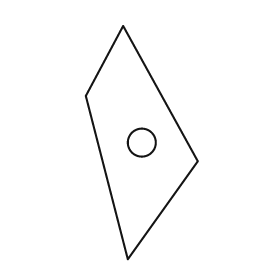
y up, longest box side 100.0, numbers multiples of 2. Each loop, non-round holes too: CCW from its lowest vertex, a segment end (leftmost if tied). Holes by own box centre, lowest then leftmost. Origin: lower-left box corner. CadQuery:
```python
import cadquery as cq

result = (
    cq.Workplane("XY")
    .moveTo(18.0, 0.0)
    .lineTo(48.0, 42.0)
    .lineTo(16.0, 100.0)
    .lineTo(0.0, 70.0)
    .close()
    .moveTo(24.0, 50.0)
    .circle(6.0)
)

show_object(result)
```